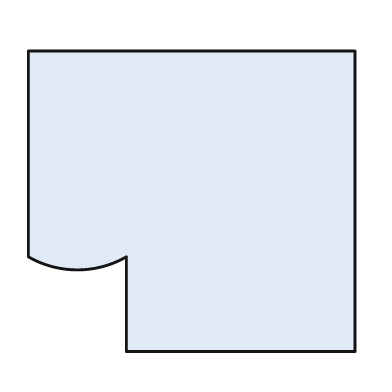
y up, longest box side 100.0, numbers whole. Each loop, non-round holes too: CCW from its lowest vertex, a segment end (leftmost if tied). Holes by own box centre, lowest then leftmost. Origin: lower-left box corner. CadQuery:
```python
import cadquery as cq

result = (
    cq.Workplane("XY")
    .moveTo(30.0, 0.0)
    .lineTo(100.0, 0.0)
    .lineTo(100.0, 92.0)
    .lineTo(0.0, 92.0)
    .lineTo(0.0, 29.0)
    .threePointArc((15.0, 25.0), (30.0, 29.0))
    .close()
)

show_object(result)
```